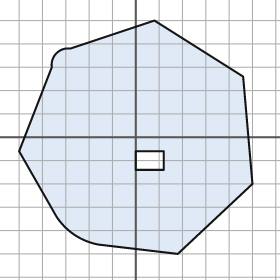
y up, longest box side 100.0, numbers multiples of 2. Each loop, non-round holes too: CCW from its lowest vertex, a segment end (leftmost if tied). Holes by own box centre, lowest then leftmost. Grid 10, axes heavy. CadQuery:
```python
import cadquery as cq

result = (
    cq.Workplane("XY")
    .moveTo(18.0, -50.0)
    .lineTo(50.0, -20.0)
    .lineTo(46.0, 26.0)
    .lineTo(8.0, 50.0)
    .lineTo(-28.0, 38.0)
    .threePointArc((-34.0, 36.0), (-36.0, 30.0))
    .lineTo(-50.0, -6.0)
    .lineTo(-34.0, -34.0)
    .threePointArc((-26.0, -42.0), (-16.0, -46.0))
    .close()
    .moveTo(0.0, -14.0)
    .lineTo(12.0, -14.0)
    .lineTo(12.0, -6.0)
    .lineTo(0.0, -6.0)
    .close()
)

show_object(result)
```